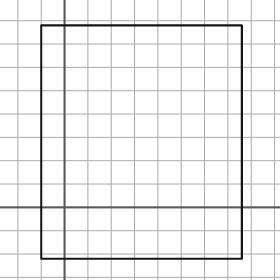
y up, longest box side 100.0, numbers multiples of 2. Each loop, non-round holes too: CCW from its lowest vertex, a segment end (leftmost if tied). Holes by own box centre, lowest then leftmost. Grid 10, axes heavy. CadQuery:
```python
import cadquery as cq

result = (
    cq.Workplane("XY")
    .moveTo(-10.0, -22.0)
    .lineTo(76.0, -22.0)
    .lineTo(76.0, 78.0)
    .lineTo(-10.0, 78.0)
    .close()
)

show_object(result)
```